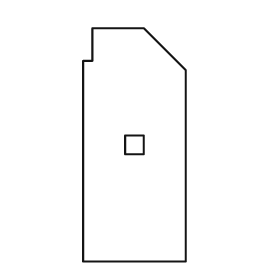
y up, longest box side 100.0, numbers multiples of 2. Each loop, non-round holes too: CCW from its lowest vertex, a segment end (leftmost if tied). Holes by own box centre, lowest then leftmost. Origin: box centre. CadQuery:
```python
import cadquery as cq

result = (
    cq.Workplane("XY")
    .moveTo(-22.0, -50.0)
    .lineTo(22.0, -50.0)
    .lineTo(22.0, 32.0)
    .lineTo(4.0, 50.0)
    .lineTo(-18.0, 50.0)
    .lineTo(-18.0, 36.0)
    .lineTo(-22.0, 36.0)
    .close()
    .moveTo(-4.0, -4.0)
    .lineTo(4.0, -4.0)
    .lineTo(4.0, 4.0)
    .lineTo(-4.0, 4.0)
    .close()
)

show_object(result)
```